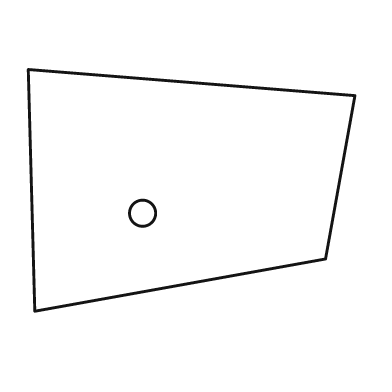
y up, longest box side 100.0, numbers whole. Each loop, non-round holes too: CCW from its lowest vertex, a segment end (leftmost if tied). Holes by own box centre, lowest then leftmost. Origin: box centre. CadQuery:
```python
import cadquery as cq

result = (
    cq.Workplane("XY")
    .moveTo(-48.0, -37.0)
    .lineTo(41.0, -21.0)
    .lineTo(50.0, 29.0)
    .lineTo(-50.0, 37.0)
    .close()
    .moveTo(-15.0, -7.0)
    .circle(4.0)
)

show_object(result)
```